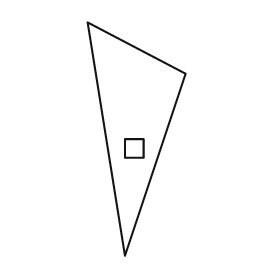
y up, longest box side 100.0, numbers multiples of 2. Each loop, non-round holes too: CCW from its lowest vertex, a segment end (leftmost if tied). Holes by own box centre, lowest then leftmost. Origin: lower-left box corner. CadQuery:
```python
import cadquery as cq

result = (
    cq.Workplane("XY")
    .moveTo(16.0, 0.0)
    .lineTo(42.0, 78.0)
    .lineTo(0.0, 100.0)
    .close()
    .moveTo(16.0, 42.0)
    .lineTo(24.0, 42.0)
    .lineTo(24.0, 50.0)
    .lineTo(16.0, 50.0)
    .close()
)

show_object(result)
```